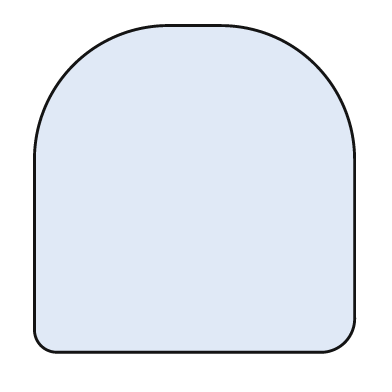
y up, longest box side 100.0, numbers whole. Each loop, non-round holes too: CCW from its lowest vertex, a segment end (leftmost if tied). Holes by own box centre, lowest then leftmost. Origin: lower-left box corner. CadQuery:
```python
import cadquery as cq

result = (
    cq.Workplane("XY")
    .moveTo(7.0, 0.0)
    .lineTo(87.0, 0.0)
    .threePointArc((95.0, 3.0), (98.0, 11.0))
    .lineTo(98.0, 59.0)
    .threePointArc((86.0, 88.0), (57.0, 100.0))
    .lineTo(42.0, 100.0)
    .threePointArc((12.0, 88.0), (0.0, 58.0))
    .lineTo(0.0, 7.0)
    .threePointArc((2.0, 2.0), (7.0, 0.0))
    .close()
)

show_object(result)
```